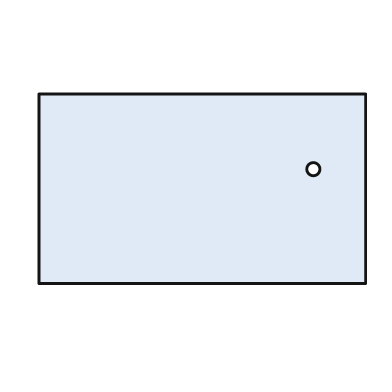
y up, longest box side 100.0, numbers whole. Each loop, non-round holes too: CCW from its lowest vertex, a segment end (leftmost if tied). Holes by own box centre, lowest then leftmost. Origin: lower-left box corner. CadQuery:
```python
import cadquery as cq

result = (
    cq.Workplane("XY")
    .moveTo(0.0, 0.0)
    .lineTo(100.0, 0.0)
    .lineTo(100.0, 58.0)
    .lineTo(0.0, 58.0)
    .close()
    .moveTo(84.0, 35.0)
    .circle(2.0)
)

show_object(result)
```